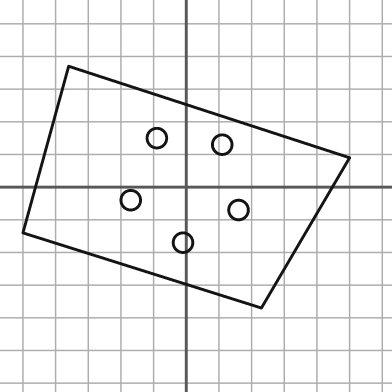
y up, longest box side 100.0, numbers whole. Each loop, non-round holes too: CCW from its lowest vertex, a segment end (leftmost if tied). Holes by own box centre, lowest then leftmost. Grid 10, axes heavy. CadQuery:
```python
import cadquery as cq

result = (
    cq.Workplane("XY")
    .moveTo(23.0, -37.0)
    .lineTo(50.0, 9.0)
    .lineTo(-36.0, 37.0)
    .lineTo(-50.0, -14.0)
    .close()
    .moveTo(-1.0, -17.0)
    .circle(3.0)
    .moveTo(16.0, -7.0)
    .circle(3.0)
    .moveTo(-17.0, -4.0)
    .circle(3.0)
    .moveTo(11.0, 13.0)
    .circle(3.0)
    .moveTo(-9.0, 15.0)
    .circle(3.0)
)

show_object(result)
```